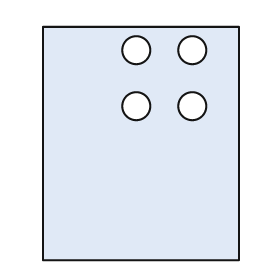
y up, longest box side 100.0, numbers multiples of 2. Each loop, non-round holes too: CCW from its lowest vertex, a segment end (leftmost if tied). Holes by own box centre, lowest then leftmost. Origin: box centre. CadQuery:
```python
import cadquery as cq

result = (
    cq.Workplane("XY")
    .moveTo(-42.0, -50.0)
    .lineTo(42.0, -50.0)
    .lineTo(42.0, 50.0)
    .lineTo(-42.0, 50.0)
    .close()
    .moveTo(-2.0, 16.0)
    .circle(6.0)
    .moveTo(22.0, 16.0)
    .circle(6.0)
    .moveTo(-2.0, 40.0)
    .circle(6.0)
    .moveTo(22.0, 40.0)
    .circle(6.0)
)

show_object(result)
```